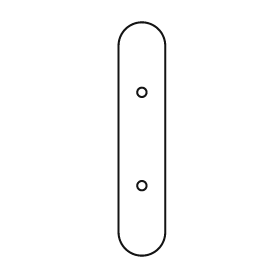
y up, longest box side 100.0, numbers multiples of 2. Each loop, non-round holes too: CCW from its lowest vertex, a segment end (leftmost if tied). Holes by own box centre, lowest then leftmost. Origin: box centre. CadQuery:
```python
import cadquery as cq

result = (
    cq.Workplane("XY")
    .moveTo(-10.0, -40.0)
    .threePointArc((0.0, -50.0), (10.0, -40.0))
    .lineTo(10.0, 40.0)
    .threePointArc((0.0, 50.0), (-10.0, 40.0))
    .close()
    .moveTo(0.0, -20.0)
    .circle(2.0)
    .moveTo(0.0, 20.0)
    .circle(2.0)
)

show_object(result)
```